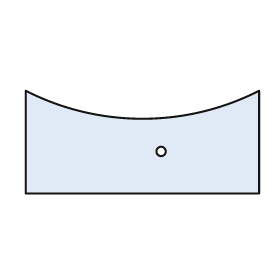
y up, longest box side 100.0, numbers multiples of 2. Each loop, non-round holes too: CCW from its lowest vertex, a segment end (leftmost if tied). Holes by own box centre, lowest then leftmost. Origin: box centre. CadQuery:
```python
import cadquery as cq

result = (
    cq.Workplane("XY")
    .moveTo(-50.0, -22.0)
    .lineTo(50.0, -22.0)
    .lineTo(50.0, 22.0)
    .threePointArc((0.0, 10.0), (-50.0, 22.0))
    .close()
    .moveTo(8.0, -4.0)
    .circle(2.0)
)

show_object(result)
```